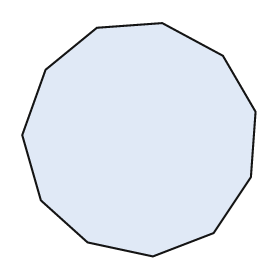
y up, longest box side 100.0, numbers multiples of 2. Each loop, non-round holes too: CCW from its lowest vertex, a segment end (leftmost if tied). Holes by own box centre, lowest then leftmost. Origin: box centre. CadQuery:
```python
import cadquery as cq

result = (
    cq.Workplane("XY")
    .moveTo(6.0, -50.0)
    .lineTo(32.0, -40.0)
    .lineTo(48.0, -16.0)
    .lineTo(50.0, 12.0)
    .lineTo(36.0, 36.0)
    .lineTo(10.0, 50.0)
    .lineTo(-18.0, 48.0)
    .lineTo(-40.0, 30.0)
    .lineTo(-50.0, 2.0)
    .lineTo(-42.0, -26.0)
    .lineTo(-22.0, -44.0)
    .close()
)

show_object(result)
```